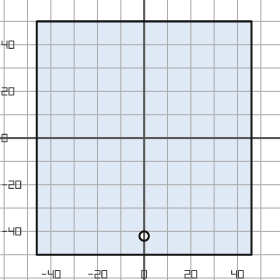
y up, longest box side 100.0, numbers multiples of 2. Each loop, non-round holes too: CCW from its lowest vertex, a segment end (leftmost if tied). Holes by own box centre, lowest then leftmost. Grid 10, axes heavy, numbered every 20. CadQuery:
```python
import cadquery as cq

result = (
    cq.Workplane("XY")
    .moveTo(-46.0, -50.0)
    .lineTo(46.0, -50.0)
    .lineTo(46.0, 50.0)
    .lineTo(-46.0, 50.0)
    .close()
    .moveTo(0.0, -42.0)
    .circle(2.0)
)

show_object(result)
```